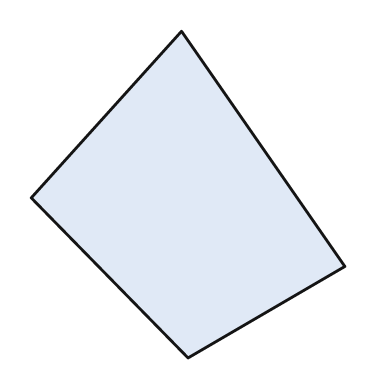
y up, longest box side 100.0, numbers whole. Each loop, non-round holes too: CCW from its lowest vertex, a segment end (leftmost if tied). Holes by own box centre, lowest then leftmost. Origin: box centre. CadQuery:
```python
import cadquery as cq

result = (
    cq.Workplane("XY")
    .moveTo(0.0, -50.0)
    .lineTo(48.0, -22.0)
    .lineTo(-2.0, 50.0)
    .lineTo(-48.0, -1.0)
    .close()
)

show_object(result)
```